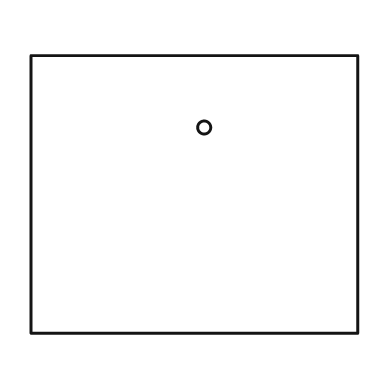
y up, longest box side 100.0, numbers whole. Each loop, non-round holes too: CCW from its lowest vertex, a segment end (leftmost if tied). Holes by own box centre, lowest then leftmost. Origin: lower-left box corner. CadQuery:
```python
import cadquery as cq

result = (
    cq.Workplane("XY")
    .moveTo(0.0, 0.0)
    .lineTo(100.0, 0.0)
    .lineTo(100.0, 85.0)
    .lineTo(0.0, 85.0)
    .close()
    .moveTo(53.0, 63.0)
    .circle(2.0)
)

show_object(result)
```